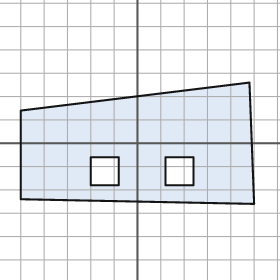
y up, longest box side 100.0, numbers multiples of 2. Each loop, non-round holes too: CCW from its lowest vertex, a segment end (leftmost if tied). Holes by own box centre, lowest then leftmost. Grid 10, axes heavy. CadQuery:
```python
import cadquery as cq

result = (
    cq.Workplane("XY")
    .moveTo(50.0, -26.0)
    .lineTo(48.0, 26.0)
    .lineTo(-50.0, 14.0)
    .lineTo(-50.0, -24.0)
    .close()
    .moveTo(-20.0, -18.0)
    .lineTo(-8.0, -18.0)
    .lineTo(-8.0, -6.0)
    .lineTo(-20.0, -6.0)
    .close()
    .moveTo(12.0, -18.0)
    .lineTo(24.0, -18.0)
    .lineTo(24.0, -6.0)
    .lineTo(12.0, -6.0)
    .close()
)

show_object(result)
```